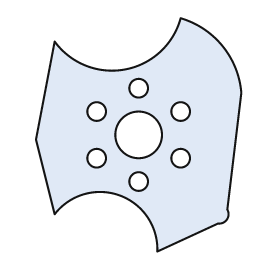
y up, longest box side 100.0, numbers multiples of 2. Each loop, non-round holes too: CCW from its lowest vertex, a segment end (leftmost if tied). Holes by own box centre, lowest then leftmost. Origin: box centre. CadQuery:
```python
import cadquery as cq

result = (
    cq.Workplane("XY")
    .moveTo(8.0, -50.0)
    .lineTo(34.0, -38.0)
    .threePointArc((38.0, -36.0), (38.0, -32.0))
    .lineTo(44.0, 18.0)
    .threePointArc((36.0, 38.0), (18.0, 50.0))
    .threePointArc((-6.0, 28.0), (-36.0, 40.0))
    .lineTo(-44.0, -2.0)
    .lineTo(-36.0, -34.0)
    .threePointArc((-8.0, -26.0), (8.0, -50.0))
    .close()
    .moveTo(0.0, -20.0)
    .circle(4.0)
    .moveTo(-18.0, -10.0)
    .circle(4.0)
    .moveTo(18.0, -10.0)
    .circle(4.0)
    .moveTo(0.0, 0.0)
    .circle(10.0)
    .moveTo(-18.0, 10.0)
    .circle(4.0)
    .moveTo(18.0, 10.0)
    .circle(4.0)
    .moveTo(0.0, 20.0)
    .circle(4.0)
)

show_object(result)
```